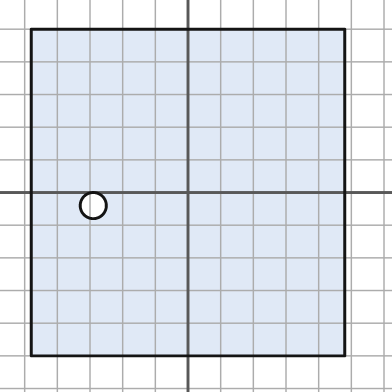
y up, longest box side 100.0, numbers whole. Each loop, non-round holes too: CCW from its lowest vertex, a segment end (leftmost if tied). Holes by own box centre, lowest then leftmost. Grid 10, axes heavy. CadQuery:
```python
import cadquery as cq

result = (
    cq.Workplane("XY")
    .moveTo(-48.0, -50.0)
    .lineTo(48.0, -50.0)
    .lineTo(48.0, 50.0)
    .lineTo(-48.0, 50.0)
    .close()
    .moveTo(-29.0, -4.0)
    .circle(4.0)
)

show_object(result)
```